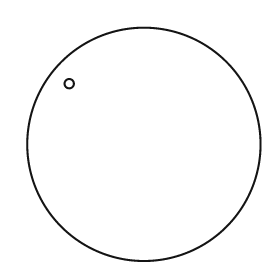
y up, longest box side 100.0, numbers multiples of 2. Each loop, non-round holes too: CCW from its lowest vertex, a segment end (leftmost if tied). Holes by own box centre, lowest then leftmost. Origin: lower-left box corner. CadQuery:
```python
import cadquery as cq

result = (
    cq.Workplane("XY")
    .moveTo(50.0, 50.0)
    .circle(50.0)
    .moveTo(18.0, 76.0)
    .circle(2.0)
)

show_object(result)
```